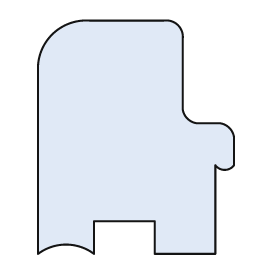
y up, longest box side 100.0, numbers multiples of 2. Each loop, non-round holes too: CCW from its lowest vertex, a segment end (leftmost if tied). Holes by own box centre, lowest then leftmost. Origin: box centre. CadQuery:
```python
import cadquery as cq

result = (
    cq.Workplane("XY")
    .moveTo(-42.0, -50.0)
    .threePointArc((-30.0, -46.0), (-18.0, -50.0))
    .lineTo(-18.0, -36.0)
    .lineTo(8.0, -36.0)
    .lineTo(8.0, -50.0)
    .lineTo(34.0, -50.0)
    .lineTo(34.0, -12.0)
    .threePointArc((38.0, -14.0), (42.0, -12.0))
    .lineTo(42.0, 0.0)
    .threePointArc((40.0, 4.0), (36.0, 6.0))
    .lineTo(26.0, 6.0)
    .threePointArc((22.0, 8.0), (20.0, 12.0))
    .lineTo(20.0, 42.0)
    .threePointArc((18.0, 48.0), (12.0, 50.0))
    .lineTo(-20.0, 50.0)
    .threePointArc((-36.0, 44.0), (-42.0, 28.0))
    .close()
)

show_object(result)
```